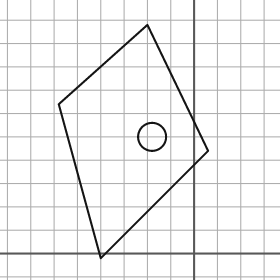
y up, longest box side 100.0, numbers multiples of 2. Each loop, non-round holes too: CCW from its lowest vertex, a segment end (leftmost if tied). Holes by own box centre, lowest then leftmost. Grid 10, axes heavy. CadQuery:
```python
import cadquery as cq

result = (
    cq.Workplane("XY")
    .moveTo(-40.0, -2.0)
    .lineTo(6.0, 44.0)
    .lineTo(-20.0, 98.0)
    .lineTo(-58.0, 64.0)
    .close()
    .moveTo(-18.0, 50.0)
    .circle(6.0)
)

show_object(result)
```